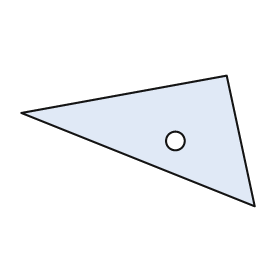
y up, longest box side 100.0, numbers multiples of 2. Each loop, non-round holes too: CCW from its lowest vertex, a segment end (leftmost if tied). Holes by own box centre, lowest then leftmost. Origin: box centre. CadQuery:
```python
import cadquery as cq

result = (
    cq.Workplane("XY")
    .moveTo(50.0, -28.0)
    .lineTo(38.0, 28.0)
    .lineTo(-50.0, 12.0)
    .close()
    .moveTo(16.0, 0.0)
    .circle(4.0)
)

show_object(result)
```